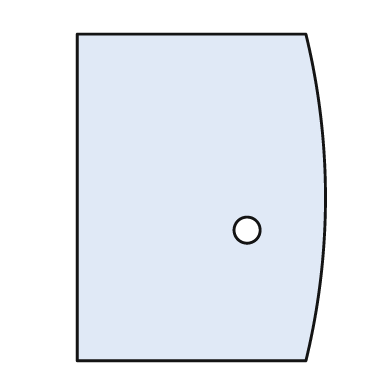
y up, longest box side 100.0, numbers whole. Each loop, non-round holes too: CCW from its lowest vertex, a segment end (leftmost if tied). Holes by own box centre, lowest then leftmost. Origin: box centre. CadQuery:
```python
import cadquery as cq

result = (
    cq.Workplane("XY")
    .moveTo(-38.0, -50.0)
    .lineTo(32.0, -50.0)
    .threePointArc((38.0, 0.0), (32.0, 50.0))
    .lineTo(-38.0, 50.0)
    .close()
    .moveTo(14.0, -10.0)
    .circle(4.0)
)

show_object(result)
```